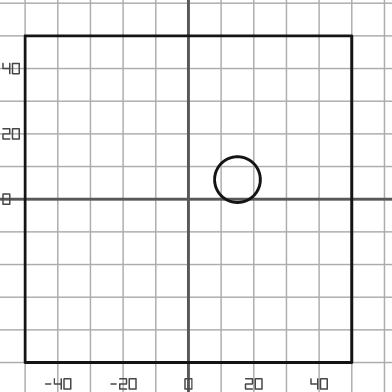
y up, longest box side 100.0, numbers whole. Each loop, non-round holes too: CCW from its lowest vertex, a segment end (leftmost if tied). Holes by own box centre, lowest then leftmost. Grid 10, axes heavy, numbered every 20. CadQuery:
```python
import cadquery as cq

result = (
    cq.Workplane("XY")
    .moveTo(-50.0, -50.0)
    .lineTo(50.0, -50.0)
    .lineTo(50.0, 50.0)
    .lineTo(-50.0, 50.0)
    .close()
    .moveTo(15.0, 6.0)
    .circle(7.0)
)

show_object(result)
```